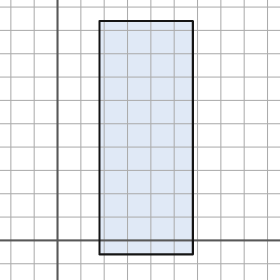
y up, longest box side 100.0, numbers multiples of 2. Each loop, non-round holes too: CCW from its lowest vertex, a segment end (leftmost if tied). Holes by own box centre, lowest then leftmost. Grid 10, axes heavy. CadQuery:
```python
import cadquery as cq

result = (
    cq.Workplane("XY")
    .moveTo(18.0, -6.0)
    .lineTo(58.0, -6.0)
    .lineTo(58.0, 94.0)
    .lineTo(18.0, 94.0)
    .close()
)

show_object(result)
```